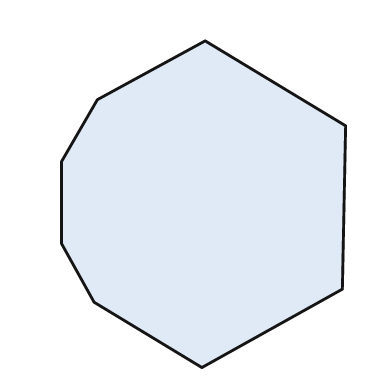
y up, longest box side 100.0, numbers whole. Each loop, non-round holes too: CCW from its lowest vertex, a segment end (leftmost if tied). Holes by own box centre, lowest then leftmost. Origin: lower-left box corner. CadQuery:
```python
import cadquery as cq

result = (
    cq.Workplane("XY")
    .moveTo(43.0, 0.0)
    .lineTo(86.0, 24.0)
    .lineTo(87.0, 74.0)
    .lineTo(44.0, 100.0)
    .lineTo(11.0, 82.0)
    .lineTo(0.0, 63.0)
    .lineTo(0.0, 38.0)
    .lineTo(10.0, 20.0)
    .close()
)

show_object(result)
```